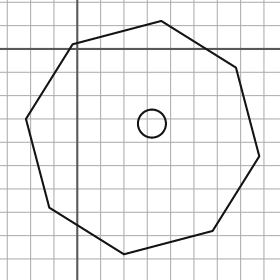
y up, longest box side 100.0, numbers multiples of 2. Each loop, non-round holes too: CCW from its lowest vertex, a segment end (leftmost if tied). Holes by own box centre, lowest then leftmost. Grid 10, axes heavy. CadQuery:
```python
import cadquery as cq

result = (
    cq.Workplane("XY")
    .moveTo(20.0, -88.0)
    .lineTo(58.0, -78.0)
    .lineTo(78.0, -46.0)
    .lineTo(68.0, -8.0)
    .lineTo(36.0, 12.0)
    .lineTo(-2.0, 2.0)
    .lineTo(-22.0, -30.0)
    .lineTo(-12.0, -68.0)
    .close()
    .moveTo(32.0, -32.0)
    .circle(6.0)
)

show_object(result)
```